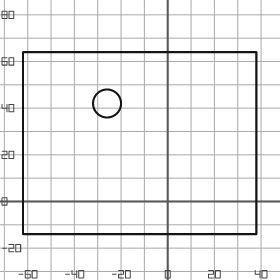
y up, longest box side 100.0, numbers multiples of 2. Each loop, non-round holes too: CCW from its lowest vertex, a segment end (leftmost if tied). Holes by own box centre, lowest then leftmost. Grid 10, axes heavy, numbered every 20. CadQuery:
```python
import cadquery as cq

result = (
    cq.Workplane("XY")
    .moveTo(-62.0, -14.0)
    .lineTo(38.0, -14.0)
    .lineTo(38.0, 64.0)
    .lineTo(-62.0, 64.0)
    .close()
    .moveTo(-26.0, 42.0)
    .circle(6.0)
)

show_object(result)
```